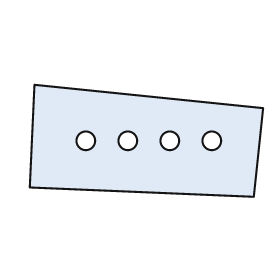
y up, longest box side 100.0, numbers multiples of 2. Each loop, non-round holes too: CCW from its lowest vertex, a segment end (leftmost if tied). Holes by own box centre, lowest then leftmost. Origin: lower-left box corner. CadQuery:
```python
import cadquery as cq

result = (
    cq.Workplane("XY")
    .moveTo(96.0, 0.0)
    .lineTo(100.0, 38.0)
    .lineTo(2.0, 48.0)
    .lineTo(0.0, 4.0)
    .close()
    .moveTo(24.0, 24.0)
    .circle(4.0)
    .moveTo(42.0, 24.0)
    .circle(4.0)
    .moveTo(60.0, 24.0)
    .circle(4.0)
    .moveTo(78.0, 24.0)
    .circle(4.0)
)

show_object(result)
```